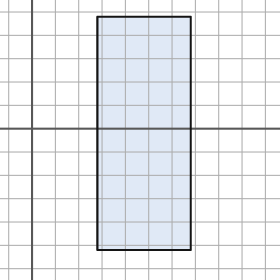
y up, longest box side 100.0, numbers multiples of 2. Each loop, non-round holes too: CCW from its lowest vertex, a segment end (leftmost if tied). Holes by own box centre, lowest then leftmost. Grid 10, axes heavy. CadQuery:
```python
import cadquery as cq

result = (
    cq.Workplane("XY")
    .moveTo(28.0, -52.0)
    .lineTo(68.0, -52.0)
    .lineTo(68.0, 48.0)
    .lineTo(28.0, 48.0)
    .close()
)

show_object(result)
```